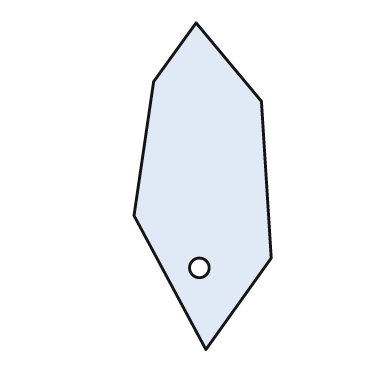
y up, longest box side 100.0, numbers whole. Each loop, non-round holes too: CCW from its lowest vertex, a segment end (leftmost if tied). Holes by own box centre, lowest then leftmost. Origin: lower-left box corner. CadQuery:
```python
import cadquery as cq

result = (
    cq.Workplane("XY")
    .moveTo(22.0, 0.0)
    .lineTo(42.0, 28.0)
    .lineTo(39.0, 76.0)
    .lineTo(19.0, 100.0)
    .lineTo(6.0, 82.0)
    .lineTo(0.0, 41.0)
    .close()
    .moveTo(20.0, 25.0)
    .circle(3.0)
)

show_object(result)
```